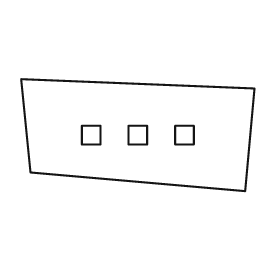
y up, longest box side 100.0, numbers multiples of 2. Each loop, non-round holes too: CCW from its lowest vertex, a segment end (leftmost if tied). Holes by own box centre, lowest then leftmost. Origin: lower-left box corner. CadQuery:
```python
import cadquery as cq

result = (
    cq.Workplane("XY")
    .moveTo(96.0, 0.0)
    .lineTo(100.0, 44.0)
    .lineTo(0.0, 48.0)
    .lineTo(4.0, 8.0)
    .close()
    .moveTo(26.0, 20.0)
    .lineTo(34.0, 20.0)
    .lineTo(34.0, 28.0)
    .lineTo(26.0, 28.0)
    .close()
    .moveTo(46.0, 20.0)
    .lineTo(54.0, 20.0)
    .lineTo(54.0, 28.0)
    .lineTo(46.0, 28.0)
    .close()
    .moveTo(66.0, 20.0)
    .lineTo(74.0, 20.0)
    .lineTo(74.0, 28.0)
    .lineTo(66.0, 28.0)
    .close()
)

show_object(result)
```